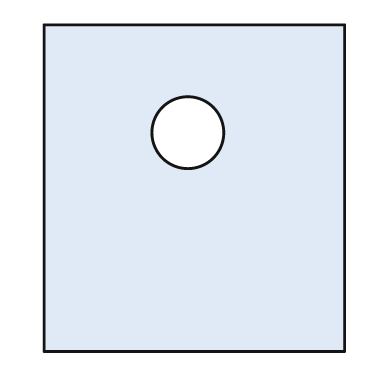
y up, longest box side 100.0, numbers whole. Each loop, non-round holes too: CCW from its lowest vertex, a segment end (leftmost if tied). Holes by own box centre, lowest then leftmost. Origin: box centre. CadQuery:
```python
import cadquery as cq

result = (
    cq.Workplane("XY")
    .moveTo(-46.0, -50.0)
    .lineTo(46.0, -50.0)
    .lineTo(46.0, 50.0)
    .lineTo(-46.0, 50.0)
    .close()
    .moveTo(-2.0, 17.0)
    .circle(11.0)
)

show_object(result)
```